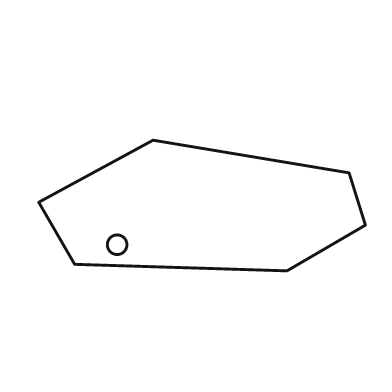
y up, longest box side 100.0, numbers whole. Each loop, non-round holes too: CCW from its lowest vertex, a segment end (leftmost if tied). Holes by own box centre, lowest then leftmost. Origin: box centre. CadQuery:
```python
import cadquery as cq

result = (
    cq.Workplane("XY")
    .moveTo(26.0, -20.0)
    .lineTo(50.0, -6.0)
    .lineTo(45.0, 10.0)
    .lineTo(-15.0, 20.0)
    .lineTo(-50.0, 1.0)
    .lineTo(-39.0, -18.0)
    .close()
    .moveTo(-26.0, -12.0)
    .circle(3.0)
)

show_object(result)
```